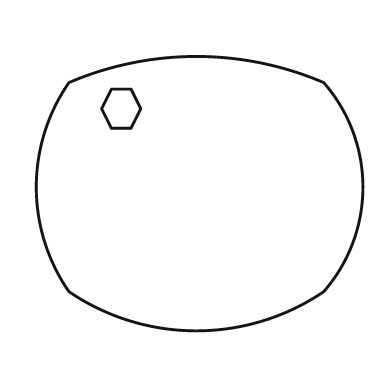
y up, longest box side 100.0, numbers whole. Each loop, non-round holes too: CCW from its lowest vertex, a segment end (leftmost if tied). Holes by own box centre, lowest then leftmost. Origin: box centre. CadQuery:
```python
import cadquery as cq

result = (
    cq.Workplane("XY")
    .moveTo(-40.0, -30.0)
    .threePointArc((-1.0, -42.0), (38.0, -30.0))
    .threePointArc((50.0, 2.0), (38.0, 34.0))
    .threePointArc((-1.0, 42.0), (-40.0, 34.0))
    .threePointArc((-50.0, 2.0), (-40.0, -30.0))
    .close()
    .moveTo(-27.0, 20.0)
    .lineTo(-21.0, 20.0)
    .lineTo(-18.0, 26.0)
    .lineTo(-21.0, 32.0)
    .lineTo(-27.0, 32.0)
    .lineTo(-30.0, 26.0)
    .close()
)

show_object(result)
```